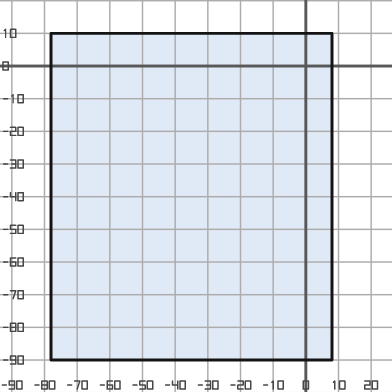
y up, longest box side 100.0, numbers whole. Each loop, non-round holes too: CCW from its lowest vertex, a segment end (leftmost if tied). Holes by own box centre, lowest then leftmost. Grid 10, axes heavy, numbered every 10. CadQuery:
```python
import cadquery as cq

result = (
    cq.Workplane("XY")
    .moveTo(-78.0, -90.0)
    .lineTo(8.0, -90.0)
    .lineTo(8.0, 10.0)
    .lineTo(-78.0, 10.0)
    .close()
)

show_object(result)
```